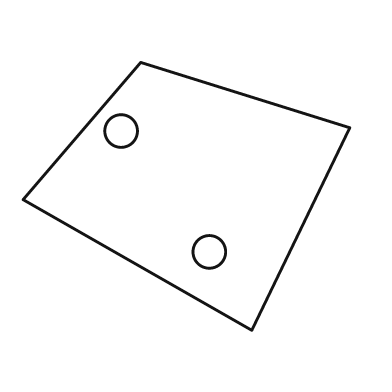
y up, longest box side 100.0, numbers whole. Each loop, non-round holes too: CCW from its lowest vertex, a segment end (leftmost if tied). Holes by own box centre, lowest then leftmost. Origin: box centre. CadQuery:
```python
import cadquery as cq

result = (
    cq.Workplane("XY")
    .moveTo(20.0, -41.0)
    .lineTo(50.0, 21.0)
    .lineTo(-14.0, 41.0)
    .lineTo(-50.0, -1.0)
    .close()
    .moveTo(7.0, -17.0)
    .circle(5.0)
    .moveTo(-20.0, 20.0)
    .circle(5.0)
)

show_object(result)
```